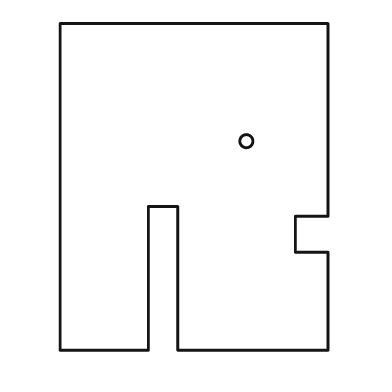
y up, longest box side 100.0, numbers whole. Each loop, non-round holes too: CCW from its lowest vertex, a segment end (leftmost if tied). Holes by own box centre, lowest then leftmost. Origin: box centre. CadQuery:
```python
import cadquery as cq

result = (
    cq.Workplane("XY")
    .moveTo(-41.0, -50.0)
    .lineTo(-14.0, -50.0)
    .lineTo(-14.0, -6.0)
    .lineTo(-5.0, -6.0)
    .lineTo(-5.0, -50.0)
    .lineTo(41.0, -50.0)
    .lineTo(41.0, -20.0)
    .lineTo(31.0, -20.0)
    .lineTo(31.0, -9.0)
    .lineTo(41.0, -9.0)
    .lineTo(41.0, 50.0)
    .lineTo(-41.0, 50.0)
    .close()
    .moveTo(16.0, 14.0)
    .circle(2.0)
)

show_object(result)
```